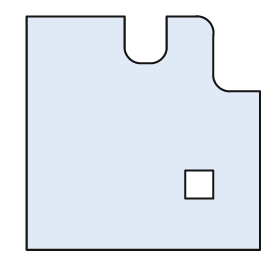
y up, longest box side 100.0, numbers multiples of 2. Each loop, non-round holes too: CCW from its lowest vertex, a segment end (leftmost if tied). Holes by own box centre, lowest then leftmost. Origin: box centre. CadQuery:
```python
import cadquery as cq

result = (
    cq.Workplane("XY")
    .moveTo(-50.0, -50.0)
    .lineTo(50.0, -50.0)
    .lineTo(50.0, 18.0)
    .lineTo(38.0, 18.0)
    .threePointArc((32.0, 20.0), (30.0, 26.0))
    .lineTo(30.0, 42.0)
    .threePointArc((28.0, 48.0), (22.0, 50.0))
    .lineTo(10.0, 50.0)
    .lineTo(10.0, 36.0)
    .threePointArc((8.0, 32.0), (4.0, 30.0))
    .lineTo(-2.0, 30.0)
    .threePointArc((-6.0, 32.0), (-8.0, 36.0))
    .lineTo(-8.0, 50.0)
    .lineTo(-50.0, 50.0)
    .close()
    .moveTo(18.0, -28.0)
    .lineTo(30.0, -28.0)
    .lineTo(30.0, -16.0)
    .lineTo(18.0, -16.0)
    .close()
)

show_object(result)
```